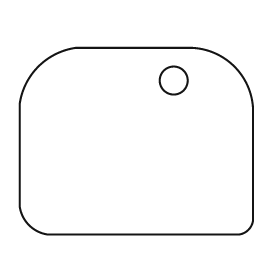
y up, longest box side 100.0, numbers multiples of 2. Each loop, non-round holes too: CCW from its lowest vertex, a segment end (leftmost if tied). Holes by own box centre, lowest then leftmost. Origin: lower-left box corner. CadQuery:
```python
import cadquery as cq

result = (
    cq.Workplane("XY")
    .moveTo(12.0, 0.0)
    .lineTo(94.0, 0.0)
    .threePointArc((98.0, 2.0), (100.0, 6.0))
    .lineTo(100.0, 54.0)
    .threePointArc((92.0, 72.0), (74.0, 80.0))
    .lineTo(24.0, 80.0)
    .threePointArc((8.0, 72.0), (0.0, 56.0))
    .lineTo(0.0, 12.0)
    .threePointArc((4.0, 4.0), (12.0, 0.0))
    .close()
    .moveTo(66.0, 66.0)
    .circle(6.0)
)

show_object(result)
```